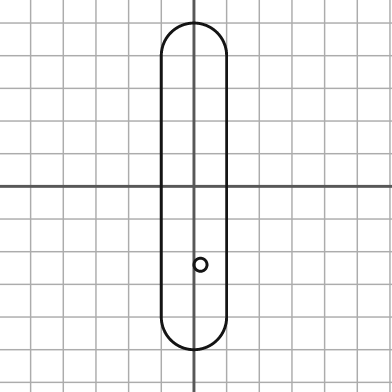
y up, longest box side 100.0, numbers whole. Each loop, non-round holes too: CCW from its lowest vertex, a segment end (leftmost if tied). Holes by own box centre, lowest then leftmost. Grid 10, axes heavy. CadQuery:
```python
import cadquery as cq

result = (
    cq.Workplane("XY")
    .moveTo(-10.0, -40.0)
    .threePointArc((0.0, -50.0), (10.0, -40.0))
    .lineTo(10.0, 40.0)
    .threePointArc((0.0, 50.0), (-10.0, 40.0))
    .close()
    .moveTo(2.0, -24.0)
    .circle(2.0)
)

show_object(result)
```